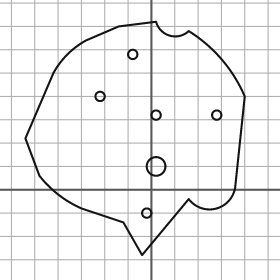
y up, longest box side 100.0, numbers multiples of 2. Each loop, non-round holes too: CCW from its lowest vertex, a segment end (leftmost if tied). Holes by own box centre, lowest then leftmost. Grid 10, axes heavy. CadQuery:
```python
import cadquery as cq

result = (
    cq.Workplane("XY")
    .moveTo(-4.0, -28.0)
    .lineTo(16.0, -4.0)
    .threePointArc((28.0, -8.0), (36.0, 2.0))
    .lineTo(40.0, 40.0)
    .threePointArc((30.0, 56.0), (16.0, 68.0))
    .threePointArc((8.0, 66.0), (2.0, 72.0))
    .lineTo(-14.0, 70.0)
    .lineTo(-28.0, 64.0)
    .threePointArc((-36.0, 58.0), (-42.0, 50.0))
    .lineTo(-54.0, 22.0)
    .lineTo(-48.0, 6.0)
    .threePointArc((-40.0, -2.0), (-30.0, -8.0))
    .lineTo(-12.0, -14.0)
    .close()
    .moveTo(-2.0, -10.0)
    .circle(2.0)
    .moveTo(2.0, 10.0)
    .circle(4.0)
    .moveTo(2.0, 32.0)
    .circle(2.0)
    .moveTo(28.0, 32.0)
    .circle(2.0)
    .moveTo(-22.0, 40.0)
    .circle(2.0)
    .moveTo(-8.0, 58.0)
    .circle(2.0)
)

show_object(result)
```